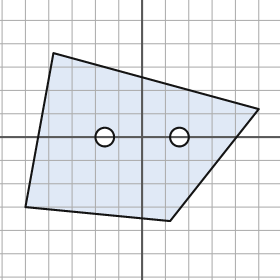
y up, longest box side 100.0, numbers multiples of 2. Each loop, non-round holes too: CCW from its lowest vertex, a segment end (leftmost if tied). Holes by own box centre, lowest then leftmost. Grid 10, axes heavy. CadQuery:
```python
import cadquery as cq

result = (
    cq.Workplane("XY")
    .moveTo(12.0, -36.0)
    .lineTo(50.0, 12.0)
    .lineTo(-38.0, 36.0)
    .lineTo(-50.0, -30.0)
    .close()
    .moveTo(-16.0, 0.0)
    .circle(4.0)
    .moveTo(16.0, 0.0)
    .circle(4.0)
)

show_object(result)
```